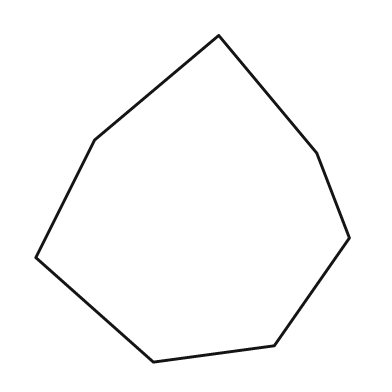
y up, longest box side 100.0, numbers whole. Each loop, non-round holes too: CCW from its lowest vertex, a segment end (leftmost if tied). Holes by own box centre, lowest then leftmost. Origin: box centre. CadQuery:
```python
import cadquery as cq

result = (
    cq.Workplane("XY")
    .moveTo(-12.0, -50.0)
    .lineTo(25.0, -45.0)
    .lineTo(48.0, -12.0)
    .lineTo(38.0, 14.0)
    .lineTo(8.0, 50.0)
    .lineTo(-30.0, 18.0)
    .lineTo(-48.0, -18.0)
    .close()
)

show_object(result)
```